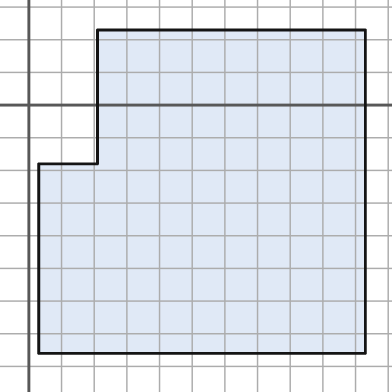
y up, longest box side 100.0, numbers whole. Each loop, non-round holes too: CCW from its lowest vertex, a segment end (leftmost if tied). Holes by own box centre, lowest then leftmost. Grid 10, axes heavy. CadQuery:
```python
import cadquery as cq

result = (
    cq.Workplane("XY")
    .moveTo(3.0, -76.0)
    .lineTo(103.0, -76.0)
    .lineTo(103.0, 23.0)
    .lineTo(21.0, 23.0)
    .lineTo(21.0, -18.0)
    .lineTo(3.0, -18.0)
    .close()
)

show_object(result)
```